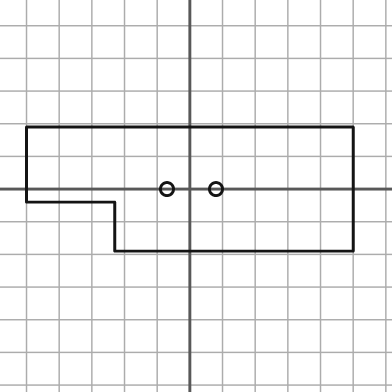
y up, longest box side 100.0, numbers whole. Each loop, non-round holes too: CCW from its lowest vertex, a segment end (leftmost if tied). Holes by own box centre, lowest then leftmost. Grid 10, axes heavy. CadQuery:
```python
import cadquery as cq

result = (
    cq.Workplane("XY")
    .moveTo(-23.0, -19.0)
    .lineTo(50.0, -19.0)
    .lineTo(50.0, 19.0)
    .lineTo(-50.0, 19.0)
    .lineTo(-50.0, -4.0)
    .lineTo(-23.0, -4.0)
    .close()
    .moveTo(-7.0, 0.0)
    .circle(2.0)
    .moveTo(8.0, 0.0)
    .circle(2.0)
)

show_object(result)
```